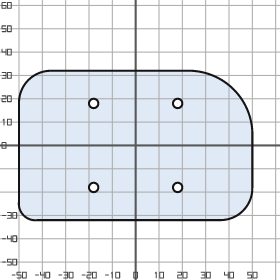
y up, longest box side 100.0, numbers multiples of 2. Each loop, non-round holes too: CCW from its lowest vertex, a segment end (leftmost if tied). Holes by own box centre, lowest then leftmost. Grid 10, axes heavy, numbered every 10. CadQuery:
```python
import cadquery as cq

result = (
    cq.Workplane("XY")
    .moveTo(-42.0, -32.0)
    .lineTo(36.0, -32.0)
    .threePointArc((46.0, -28.0), (50.0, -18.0))
    .lineTo(50.0, 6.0)
    .threePointArc((42.0, 24.0), (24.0, 32.0))
    .lineTo(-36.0, 32.0)
    .threePointArc((-46.0, 28.0), (-50.0, 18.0))
    .lineTo(-50.0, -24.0)
    .threePointArc((-48.0, -30.0), (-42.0, -32.0))
    .close()
    .moveTo(-18.0, -18.0)
    .circle(2.0)
    .moveTo(18.0, -18.0)
    .circle(2.0)
    .moveTo(-18.0, 18.0)
    .circle(2.0)
    .moveTo(18.0, 18.0)
    .circle(2.0)
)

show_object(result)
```